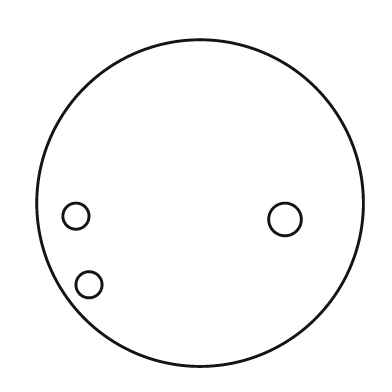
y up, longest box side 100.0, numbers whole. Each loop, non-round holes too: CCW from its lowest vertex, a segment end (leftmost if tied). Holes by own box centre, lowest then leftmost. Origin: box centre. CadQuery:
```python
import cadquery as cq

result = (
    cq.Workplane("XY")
    .moveTo(0.0, 0.0)
    .circle(50.0)
    .moveTo(-34.0, -25.0)
    .circle(4.0)
    .moveTo(26.0, -5.0)
    .circle(5.0)
    .moveTo(-38.0, -4.0)
    .circle(4.0)
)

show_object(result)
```